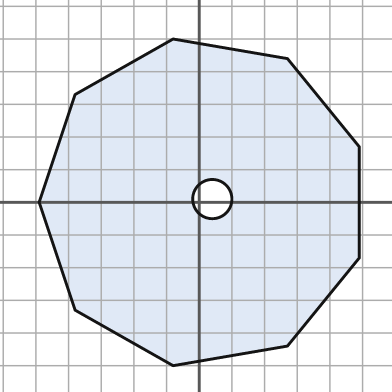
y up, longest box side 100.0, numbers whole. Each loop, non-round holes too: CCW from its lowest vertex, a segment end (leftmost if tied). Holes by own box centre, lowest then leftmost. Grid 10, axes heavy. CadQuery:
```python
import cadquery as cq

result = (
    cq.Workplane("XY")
    .moveTo(-8.0, -50.0)
    .lineTo(27.0, -44.0)
    .lineTo(49.0, -17.0)
    .lineTo(49.0, 17.0)
    .lineTo(27.0, 44.0)
    .lineTo(-8.0, 50.0)
    .lineTo(-38.0, 33.0)
    .lineTo(-49.0, 0.0)
    .lineTo(-38.0, -33.0)
    .close()
    .moveTo(4.0, 1.0)
    .circle(6.0)
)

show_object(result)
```